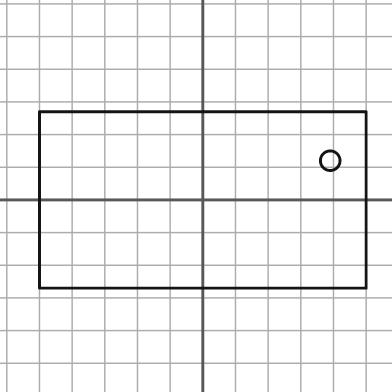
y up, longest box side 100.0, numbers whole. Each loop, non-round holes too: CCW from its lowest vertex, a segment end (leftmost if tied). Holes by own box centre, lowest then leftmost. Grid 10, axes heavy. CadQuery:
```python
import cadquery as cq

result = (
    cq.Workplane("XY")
    .moveTo(-50.0, -27.0)
    .lineTo(50.0, -27.0)
    .lineTo(50.0, 27.0)
    .lineTo(-50.0, 27.0)
    .close()
    .moveTo(39.0, 12.0)
    .circle(3.0)
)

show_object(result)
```